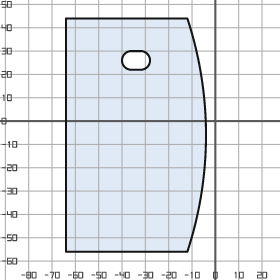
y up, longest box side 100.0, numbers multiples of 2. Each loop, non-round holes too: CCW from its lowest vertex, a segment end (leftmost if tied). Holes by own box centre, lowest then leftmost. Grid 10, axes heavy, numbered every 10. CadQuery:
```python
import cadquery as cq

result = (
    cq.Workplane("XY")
    .moveTo(-64.0, -56.0)
    .lineTo(-12.0, -56.0)
    .threePointArc((-4.0, -6.0), (-12.0, 44.0))
    .lineTo(-64.0, 44.0)
    .close()
    .moveTo(-36.0, 22.0)
    .lineTo(-32.0, 22.0)
    .threePointArc((-28.0, 26.0), (-32.0, 30.0))
    .lineTo(-36.0, 30.0)
    .threePointArc((-40.0, 26.0), (-36.0, 22.0))
    .close()
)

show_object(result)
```